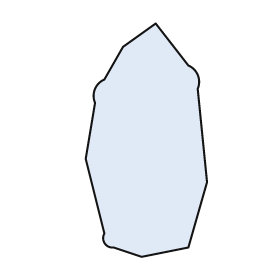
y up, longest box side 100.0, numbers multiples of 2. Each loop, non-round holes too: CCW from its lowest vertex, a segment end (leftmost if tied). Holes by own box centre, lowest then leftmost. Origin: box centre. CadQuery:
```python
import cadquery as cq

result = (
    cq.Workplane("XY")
    .moveTo(-2.0, -50.0)
    .lineTo(18.0, -46.0)
    .lineTo(26.0, -18.0)
    .lineTo(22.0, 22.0)
    .threePointArc((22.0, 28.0), (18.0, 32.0))
    .lineTo(4.0, 50.0)
    .lineTo(-10.0, 40.0)
    .lineTo(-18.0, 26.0)
    .threePointArc((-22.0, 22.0), (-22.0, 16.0))
    .lineTo(-26.0, -8.0)
    .lineTo(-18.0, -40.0)
    .threePointArc((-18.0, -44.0), (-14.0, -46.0))
    .close()
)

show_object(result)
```